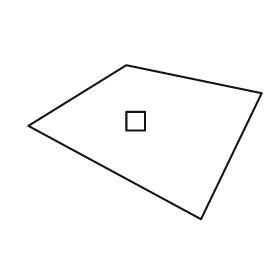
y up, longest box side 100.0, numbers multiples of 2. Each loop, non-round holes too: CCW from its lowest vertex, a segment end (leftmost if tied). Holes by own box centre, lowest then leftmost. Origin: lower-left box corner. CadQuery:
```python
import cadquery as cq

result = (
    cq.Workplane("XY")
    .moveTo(74.0, 0.0)
    .lineTo(100.0, 54.0)
    .lineTo(42.0, 66.0)
    .lineTo(0.0, 40.0)
    .close()
    .moveTo(42.0, 38.0)
    .lineTo(50.0, 38.0)
    .lineTo(50.0, 46.0)
    .lineTo(42.0, 46.0)
    .close()
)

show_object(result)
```